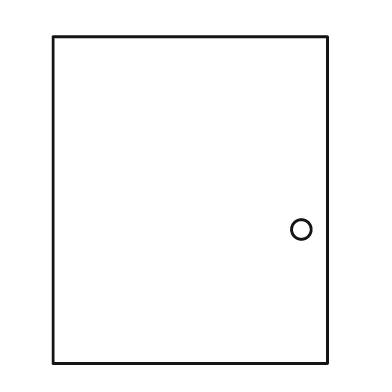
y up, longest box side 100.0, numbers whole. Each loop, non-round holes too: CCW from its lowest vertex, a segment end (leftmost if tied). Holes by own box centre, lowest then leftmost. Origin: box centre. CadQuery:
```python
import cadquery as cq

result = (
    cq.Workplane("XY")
    .moveTo(-42.0, -50.0)
    .lineTo(42.0, -50.0)
    .lineTo(42.0, 50.0)
    .lineTo(-42.0, 50.0)
    .close()
    .moveTo(34.0, -9.0)
    .circle(3.0)
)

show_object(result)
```